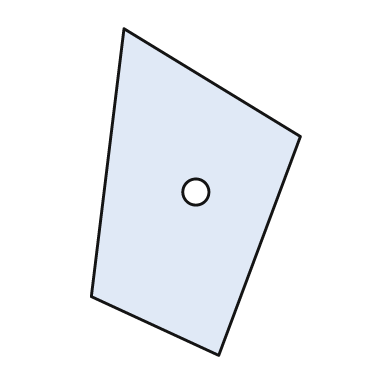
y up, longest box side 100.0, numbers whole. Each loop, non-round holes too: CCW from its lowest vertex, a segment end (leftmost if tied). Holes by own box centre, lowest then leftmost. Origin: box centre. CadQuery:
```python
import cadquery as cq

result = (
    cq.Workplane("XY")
    .moveTo(7.0, -50.0)
    .lineTo(32.0, 17.0)
    .lineTo(-22.0, 50.0)
    .lineTo(-32.0, -32.0)
    .close()
    .moveTo(0.0, 0.0)
    .circle(4.0)
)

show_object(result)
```